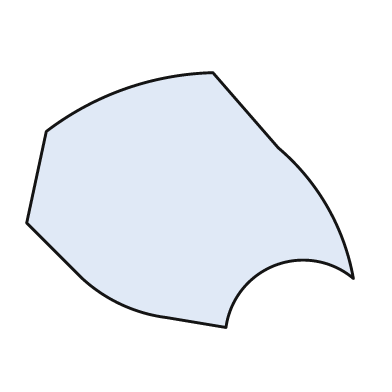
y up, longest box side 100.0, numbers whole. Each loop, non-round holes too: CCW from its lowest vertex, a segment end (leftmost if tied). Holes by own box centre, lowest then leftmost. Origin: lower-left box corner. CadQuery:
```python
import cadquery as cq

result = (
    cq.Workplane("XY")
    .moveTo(61.0, 0.0)
    .threePointArc((76.0, 19.0), (100.0, 15.0))
    .threePointArc((92.0, 37.0), (77.0, 55.0))
    .lineTo(57.0, 78.0)
    .threePointArc((30.0, 73.0), (6.0, 60.0))
    .lineTo(0.0, 32.0)
    .lineTo(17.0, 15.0)
    .threePointArc((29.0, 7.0), (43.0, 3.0))
    .close()
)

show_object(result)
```